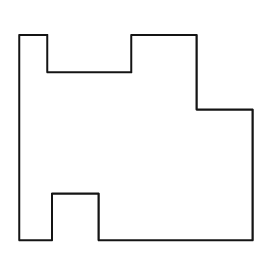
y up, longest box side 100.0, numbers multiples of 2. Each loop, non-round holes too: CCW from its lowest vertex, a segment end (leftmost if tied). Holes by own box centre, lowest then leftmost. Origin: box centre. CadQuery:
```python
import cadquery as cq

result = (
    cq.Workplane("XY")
    .moveTo(-50.0, -44.0)
    .lineTo(-36.0, -44.0)
    .lineTo(-36.0, -24.0)
    .lineTo(-16.0, -24.0)
    .lineTo(-16.0, -44.0)
    .lineTo(50.0, -44.0)
    .lineTo(50.0, 12.0)
    .lineTo(26.0, 12.0)
    .lineTo(26.0, 44.0)
    .lineTo(-2.0, 44.0)
    .lineTo(-2.0, 28.0)
    .lineTo(-38.0, 28.0)
    .lineTo(-38.0, 44.0)
    .lineTo(-50.0, 44.0)
    .close()
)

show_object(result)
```